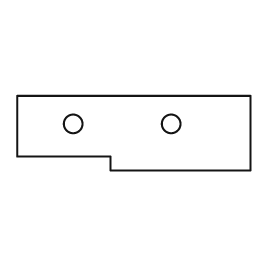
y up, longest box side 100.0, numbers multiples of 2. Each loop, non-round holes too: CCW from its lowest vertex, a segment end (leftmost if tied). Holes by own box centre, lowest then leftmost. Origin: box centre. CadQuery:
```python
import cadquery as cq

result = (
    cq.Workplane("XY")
    .moveTo(-10.0, -16.0)
    .lineTo(50.0, -16.0)
    .lineTo(50.0, 16.0)
    .lineTo(-50.0, 16.0)
    .lineTo(-50.0, -10.0)
    .lineTo(-10.0, -10.0)
    .close()
    .moveTo(-26.0, 4.0)
    .circle(4.0)
    .moveTo(16.0, 4.0)
    .circle(4.0)
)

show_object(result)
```